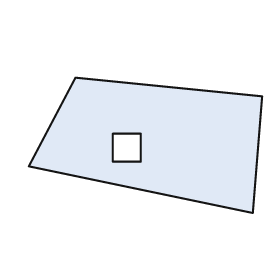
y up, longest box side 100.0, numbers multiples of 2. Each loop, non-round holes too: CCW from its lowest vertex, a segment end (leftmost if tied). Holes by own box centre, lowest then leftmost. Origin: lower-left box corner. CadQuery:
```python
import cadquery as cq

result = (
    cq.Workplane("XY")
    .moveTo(96.0, 0.0)
    .lineTo(100.0, 50.0)
    .lineTo(20.0, 58.0)
    .lineTo(0.0, 20.0)
    .close()
    .moveTo(36.0, 22.0)
    .lineTo(48.0, 22.0)
    .lineTo(48.0, 34.0)
    .lineTo(36.0, 34.0)
    .close()
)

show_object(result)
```